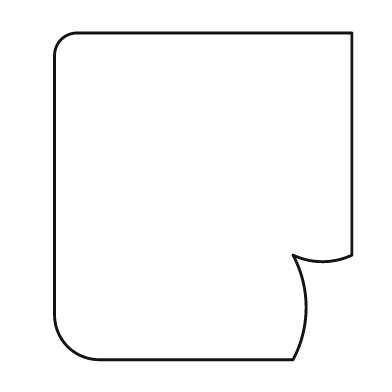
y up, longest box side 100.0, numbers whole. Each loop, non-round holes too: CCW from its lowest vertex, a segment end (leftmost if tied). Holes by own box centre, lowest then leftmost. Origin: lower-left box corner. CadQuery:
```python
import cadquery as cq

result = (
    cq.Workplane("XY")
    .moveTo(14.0, 0.0)
    .lineTo(73.0, 0.0)
    .threePointArc((77.0, 16.0), (73.0, 32.0))
    .threePointArc((82.0, 30.0), (91.0, 32.0))
    .lineTo(91.0, 100.0)
    .lineTo(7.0, 100.0)
    .threePointArc((2.0, 98.0), (0.0, 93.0))
    .lineTo(0.0, 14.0)
    .threePointArc((4.0, 4.0), (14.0, 0.0))
    .close()
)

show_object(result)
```